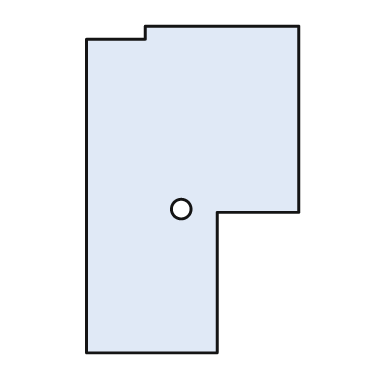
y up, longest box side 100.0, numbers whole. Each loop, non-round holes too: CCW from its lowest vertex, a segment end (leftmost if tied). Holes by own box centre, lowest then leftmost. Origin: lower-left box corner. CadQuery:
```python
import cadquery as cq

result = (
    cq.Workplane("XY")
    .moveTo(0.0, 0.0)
    .lineTo(40.0, 0.0)
    .lineTo(40.0, 43.0)
    .lineTo(65.0, 43.0)
    .lineTo(65.0, 100.0)
    .lineTo(18.0, 100.0)
    .lineTo(18.0, 96.0)
    .lineTo(0.0, 96.0)
    .close()
    .moveTo(29.0, 44.0)
    .circle(3.0)
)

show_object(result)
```